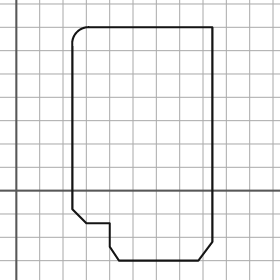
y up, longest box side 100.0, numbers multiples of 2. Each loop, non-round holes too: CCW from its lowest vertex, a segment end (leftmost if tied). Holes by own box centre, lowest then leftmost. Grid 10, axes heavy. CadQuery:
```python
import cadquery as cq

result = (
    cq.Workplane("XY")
    .moveTo(44.0, -30.0)
    .lineTo(78.0, -30.0)
    .lineTo(84.0, -22.0)
    .lineTo(84.0, 70.0)
    .lineTo(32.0, 70.0)
    .threePointArc((26.0, 68.0), (24.0, 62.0))
    .lineTo(24.0, -8.0)
    .lineTo(30.0, -14.0)
    .lineTo(40.0, -14.0)
    .lineTo(40.0, -24.0)
    .close()
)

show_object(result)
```